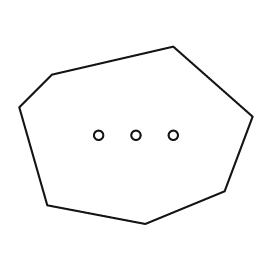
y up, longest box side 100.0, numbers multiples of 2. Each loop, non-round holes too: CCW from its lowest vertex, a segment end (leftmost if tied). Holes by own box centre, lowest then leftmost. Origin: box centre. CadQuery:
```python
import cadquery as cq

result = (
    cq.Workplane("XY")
    .moveTo(4.0, -38.0)
    .lineTo(38.0, -24.0)
    .lineTo(50.0, 8.0)
    .lineTo(16.0, 38.0)
    .lineTo(-36.0, 26.0)
    .lineTo(-50.0, 12.0)
    .lineTo(-38.0, -30.0)
    .close()
    .moveTo(-16.0, 0.0)
    .circle(2.0)
    .moveTo(0.0, 0.0)
    .circle(2.0)
    .moveTo(16.0, 0.0)
    .circle(2.0)
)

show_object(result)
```